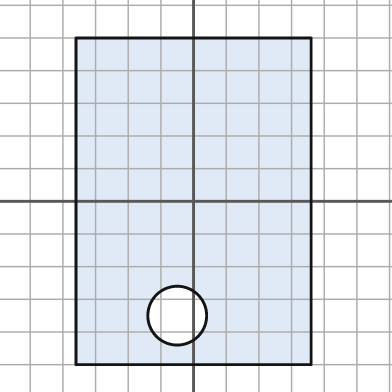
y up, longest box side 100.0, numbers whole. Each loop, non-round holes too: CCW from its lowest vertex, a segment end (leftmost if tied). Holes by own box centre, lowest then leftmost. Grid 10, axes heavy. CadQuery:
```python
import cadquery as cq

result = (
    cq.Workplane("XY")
    .moveTo(-36.0, -50.0)
    .lineTo(36.0, -50.0)
    .lineTo(36.0, 50.0)
    .lineTo(-36.0, 50.0)
    .close()
    .moveTo(-5.0, -35.0)
    .circle(9.0)
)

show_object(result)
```